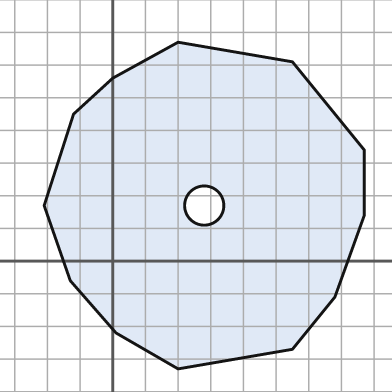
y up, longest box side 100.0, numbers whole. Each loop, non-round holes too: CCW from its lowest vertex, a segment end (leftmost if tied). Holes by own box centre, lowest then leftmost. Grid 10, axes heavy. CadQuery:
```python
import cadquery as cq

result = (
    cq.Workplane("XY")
    .moveTo(20.0, -33.0)
    .lineTo(55.0, -27.0)
    .lineTo(68.0, -11.0)
    .lineTo(77.0, 14.0)
    .lineTo(77.0, 34.0)
    .lineTo(55.0, 61.0)
    .lineTo(20.0, 67.0)
    .lineTo(0.0, 56.0)
    .lineTo(-12.0, 45.0)
    .lineTo(-21.0, 17.0)
    .lineTo(-13.0, -6.0)
    .lineTo(1.0, -22.0)
    .close()
    .moveTo(28.0, 17.0)
    .circle(6.0)
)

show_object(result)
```